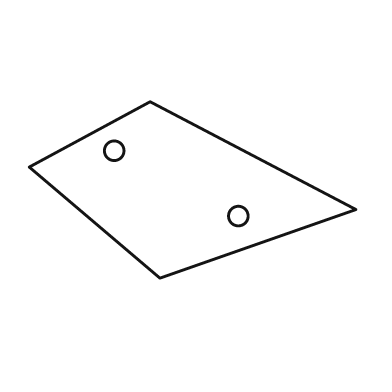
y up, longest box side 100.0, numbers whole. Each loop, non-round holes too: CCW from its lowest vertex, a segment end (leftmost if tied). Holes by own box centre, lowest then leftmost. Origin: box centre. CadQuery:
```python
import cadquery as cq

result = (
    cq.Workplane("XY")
    .moveTo(-10.0, -27.0)
    .lineTo(50.0, -6.0)
    .lineTo(-13.0, 27.0)
    .lineTo(-50.0, 7.0)
    .close()
    .moveTo(14.0, -8.0)
    .circle(3.0)
    .moveTo(-24.0, 12.0)
    .circle(3.0)
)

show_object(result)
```